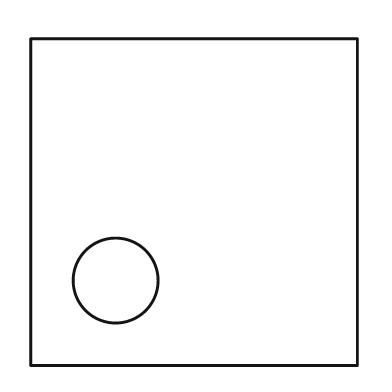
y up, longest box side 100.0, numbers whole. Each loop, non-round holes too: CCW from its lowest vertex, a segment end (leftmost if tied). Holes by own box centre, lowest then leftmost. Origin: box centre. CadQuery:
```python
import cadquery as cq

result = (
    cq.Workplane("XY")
    .moveTo(-50.0, -50.0)
    .lineTo(50.0, -50.0)
    .lineTo(50.0, 50.0)
    .lineTo(-50.0, 50.0)
    .close()
    .moveTo(-24.0, -24.0)
    .circle(13.0)
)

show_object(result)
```